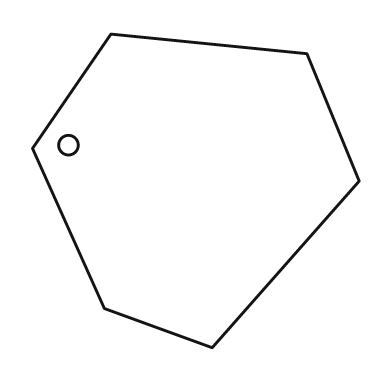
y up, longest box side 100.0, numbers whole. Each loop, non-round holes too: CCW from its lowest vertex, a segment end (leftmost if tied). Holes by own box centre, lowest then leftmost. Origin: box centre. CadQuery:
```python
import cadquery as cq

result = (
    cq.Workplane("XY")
    .moveTo(5.0, -48.0)
    .lineTo(50.0, 3.0)
    .lineTo(34.0, 42.0)
    .lineTo(-26.0, 48.0)
    .lineTo(-50.0, 13.0)
    .lineTo(-28.0, -36.0)
    .close()
    .moveTo(-39.0, 14.0)
    .circle(3.0)
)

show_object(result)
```